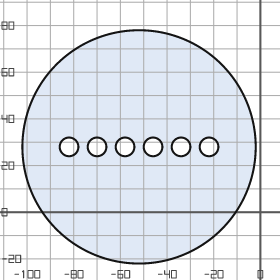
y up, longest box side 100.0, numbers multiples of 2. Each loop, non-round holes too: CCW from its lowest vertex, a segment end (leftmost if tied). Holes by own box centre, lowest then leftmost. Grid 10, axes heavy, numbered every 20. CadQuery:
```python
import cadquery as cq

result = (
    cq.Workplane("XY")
    .moveTo(-52.0, 28.0)
    .circle(50.0)
    .moveTo(-82.0, 28.0)
    .circle(4.0)
    .moveTo(-70.0, 28.0)
    .circle(4.0)
    .moveTo(-58.0, 28.0)
    .circle(4.0)
    .moveTo(-46.0, 28.0)
    .circle(4.0)
    .moveTo(-34.0, 28.0)
    .circle(4.0)
    .moveTo(-22.0, 28.0)
    .circle(4.0)
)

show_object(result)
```